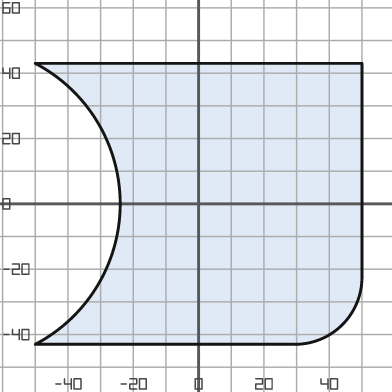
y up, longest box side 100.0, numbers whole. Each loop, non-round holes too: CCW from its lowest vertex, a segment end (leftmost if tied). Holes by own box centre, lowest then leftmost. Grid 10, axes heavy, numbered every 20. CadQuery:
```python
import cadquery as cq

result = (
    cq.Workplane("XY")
    .moveTo(-50.0, -43.0)
    .lineTo(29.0, -43.0)
    .threePointArc((44.0, -37.0), (50.0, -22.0))
    .lineTo(50.0, 43.0)
    .lineTo(-50.0, 43.0)
    .threePointArc((-24.0, 0.0), (-50.0, -43.0))
    .close()
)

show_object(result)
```